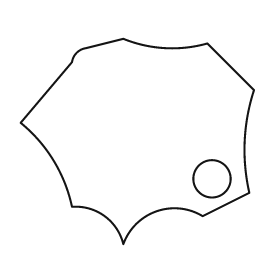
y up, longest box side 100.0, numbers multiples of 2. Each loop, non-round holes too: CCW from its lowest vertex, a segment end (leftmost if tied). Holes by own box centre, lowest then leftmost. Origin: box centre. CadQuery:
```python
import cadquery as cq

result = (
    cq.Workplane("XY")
    .moveTo(-6.0, -44.0)
    .threePointArc((8.0, -30.0), (28.0, -32.0))
    .lineTo(48.0, -22.0)
    .threePointArc((46.0, 0.0), (50.0, 22.0))
    .lineTo(30.0, 42.0)
    .threePointArc((12.0, 40.0), (-6.0, 44.0))
    .lineTo(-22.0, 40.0)
    .threePointArc((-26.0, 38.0), (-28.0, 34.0))
    .lineTo(-50.0, 8.0)
    .threePointArc((-36.0, -8.0), (-28.0, -28.0))
    .threePointArc((-14.0, -32.0), (-6.0, -44.0))
    .close()
    .moveTo(32.0, -16.0)
    .circle(8.0)
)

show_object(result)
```